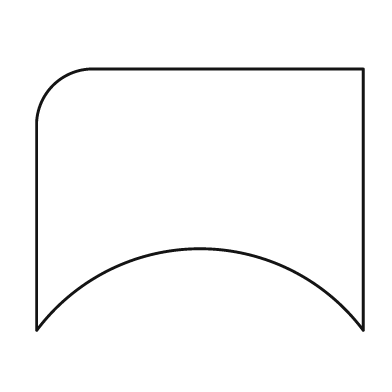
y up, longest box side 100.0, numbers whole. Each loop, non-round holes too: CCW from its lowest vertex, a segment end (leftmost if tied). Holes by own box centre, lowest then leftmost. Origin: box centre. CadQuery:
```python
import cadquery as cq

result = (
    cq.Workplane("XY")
    .moveTo(-50.0, -40.0)
    .threePointArc((0.0, -15.0), (50.0, -40.0))
    .lineTo(50.0, 40.0)
    .lineTo(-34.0, 40.0)
    .threePointArc((-45.0, 35.0), (-50.0, 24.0))
    .close()
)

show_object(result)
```